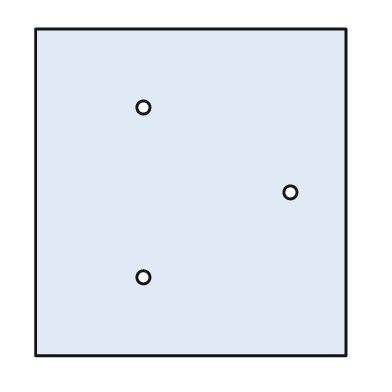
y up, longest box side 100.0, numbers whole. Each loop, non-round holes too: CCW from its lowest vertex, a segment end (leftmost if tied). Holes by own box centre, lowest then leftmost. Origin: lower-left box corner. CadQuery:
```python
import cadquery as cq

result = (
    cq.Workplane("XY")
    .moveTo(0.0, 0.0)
    .lineTo(95.0, 0.0)
    .lineTo(95.0, 100.0)
    .lineTo(0.0, 100.0)
    .close()
    .moveTo(33.0, 24.0)
    .circle(2.0)
    .moveTo(78.0, 50.0)
    .circle(2.0)
    .moveTo(33.0, 76.0)
    .circle(2.0)
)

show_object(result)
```